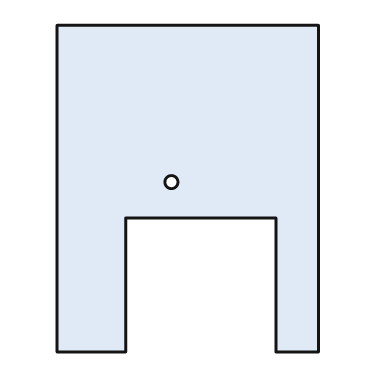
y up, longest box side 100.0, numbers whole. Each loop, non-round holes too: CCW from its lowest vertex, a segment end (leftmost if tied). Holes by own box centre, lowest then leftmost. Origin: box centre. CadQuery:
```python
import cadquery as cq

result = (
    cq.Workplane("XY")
    .moveTo(-40.0, -50.0)
    .lineTo(-19.0, -50.0)
    .lineTo(-19.0, -9.0)
    .lineTo(27.0, -9.0)
    .lineTo(27.0, -50.0)
    .lineTo(40.0, -50.0)
    .lineTo(40.0, 50.0)
    .lineTo(-40.0, 50.0)
    .close()
    .moveTo(-5.0, 2.0)
    .circle(2.0)
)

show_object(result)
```